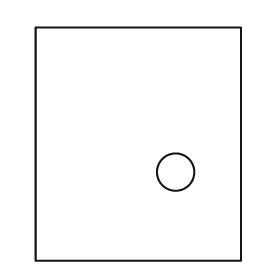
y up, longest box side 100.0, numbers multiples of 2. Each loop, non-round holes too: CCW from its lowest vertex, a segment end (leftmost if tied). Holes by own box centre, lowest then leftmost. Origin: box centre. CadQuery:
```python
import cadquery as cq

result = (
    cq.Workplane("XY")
    .moveTo(-44.0, -50.0)
    .lineTo(44.0, -50.0)
    .lineTo(44.0, 50.0)
    .lineTo(-44.0, 50.0)
    .close()
    .moveTo(16.0, -12.0)
    .circle(8.0)
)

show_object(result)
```